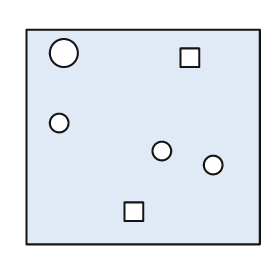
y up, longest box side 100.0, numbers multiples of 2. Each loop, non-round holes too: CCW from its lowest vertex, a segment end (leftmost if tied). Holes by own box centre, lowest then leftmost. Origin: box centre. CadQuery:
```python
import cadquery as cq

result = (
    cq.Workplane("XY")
    .moveTo(-50.0, -46.0)
    .lineTo(50.0, -46.0)
    .lineTo(50.0, 46.0)
    .lineTo(-50.0, 46.0)
    .close()
    .moveTo(-8.0, -36.0)
    .lineTo(0.0, -36.0)
    .lineTo(0.0, -28.0)
    .lineTo(-8.0, -28.0)
    .close()
    .moveTo(30.0, -12.0)
    .circle(4.0)
    .moveTo(8.0, -6.0)
    .circle(4.0)
    .moveTo(-36.0, 6.0)
    .circle(4.0)
    .moveTo(16.0, 30.0)
    .lineTo(24.0, 30.0)
    .lineTo(24.0, 38.0)
    .lineTo(16.0, 38.0)
    .close()
    .moveTo(-34.0, 36.0)
    .circle(6.0)
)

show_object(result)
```